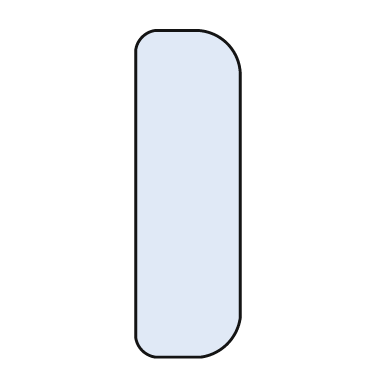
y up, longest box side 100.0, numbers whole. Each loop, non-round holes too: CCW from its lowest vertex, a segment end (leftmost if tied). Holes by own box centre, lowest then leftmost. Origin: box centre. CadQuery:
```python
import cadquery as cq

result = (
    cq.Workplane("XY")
    .moveTo(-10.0, -50.0)
    .lineTo(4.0, -50.0)
    .threePointArc((12.0, -46.0), (16.0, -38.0))
    .lineTo(16.0, 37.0)
    .threePointArc((12.0, 46.0), (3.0, 50.0))
    .lineTo(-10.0, 50.0)
    .threePointArc((-14.0, 48.0), (-16.0, 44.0))
    .lineTo(-16.0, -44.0)
    .threePointArc((-14.0, -48.0), (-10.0, -50.0))
    .close()
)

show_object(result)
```